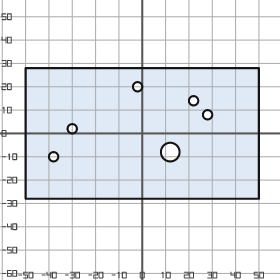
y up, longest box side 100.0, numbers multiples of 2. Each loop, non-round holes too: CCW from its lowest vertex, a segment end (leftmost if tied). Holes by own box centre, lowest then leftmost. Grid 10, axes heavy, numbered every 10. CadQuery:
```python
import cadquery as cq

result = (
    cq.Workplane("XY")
    .moveTo(-50.0, -28.0)
    .lineTo(50.0, -28.0)
    .lineTo(50.0, 28.0)
    .lineTo(-50.0, 28.0)
    .close()
    .moveTo(-38.0, -10.0)
    .circle(2.0)
    .moveTo(12.0, -8.0)
    .circle(4.0)
    .moveTo(-30.0, 2.0)
    .circle(2.0)
    .moveTo(28.0, 8.0)
    .circle(2.0)
    .moveTo(22.0, 14.0)
    .circle(2.0)
    .moveTo(-2.0, 20.0)
    .circle(2.0)
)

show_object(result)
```